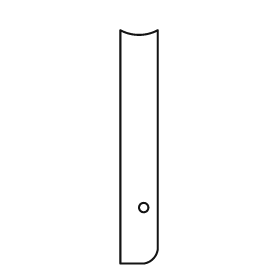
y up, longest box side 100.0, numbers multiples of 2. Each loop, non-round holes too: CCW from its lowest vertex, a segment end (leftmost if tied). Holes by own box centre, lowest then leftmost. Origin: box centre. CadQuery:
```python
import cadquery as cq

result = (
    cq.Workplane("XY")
    .moveTo(-8.0, -50.0)
    .lineTo(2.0, -50.0)
    .threePointArc((6.0, -48.0), (8.0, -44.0))
    .lineTo(8.0, 50.0)
    .threePointArc((0.0, 48.0), (-8.0, 50.0))
    .close()
    .moveTo(2.0, -26.0)
    .circle(2.0)
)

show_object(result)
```